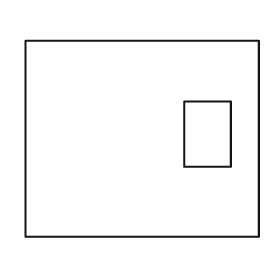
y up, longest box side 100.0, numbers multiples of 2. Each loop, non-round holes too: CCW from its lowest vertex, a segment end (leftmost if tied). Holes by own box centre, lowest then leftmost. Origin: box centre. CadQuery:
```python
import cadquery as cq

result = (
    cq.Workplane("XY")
    .moveTo(-50.0, -42.0)
    .lineTo(50.0, -42.0)
    .lineTo(50.0, 42.0)
    .lineTo(-50.0, 42.0)
    .close()
    .moveTo(18.0, -12.0)
    .lineTo(38.0, -12.0)
    .lineTo(38.0, 16.0)
    .lineTo(18.0, 16.0)
    .close()
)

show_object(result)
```